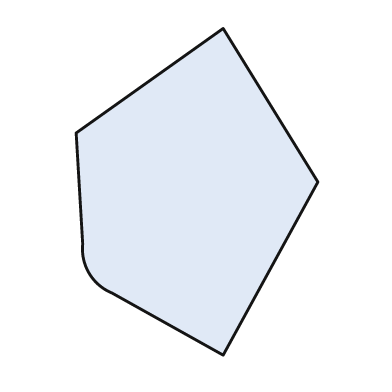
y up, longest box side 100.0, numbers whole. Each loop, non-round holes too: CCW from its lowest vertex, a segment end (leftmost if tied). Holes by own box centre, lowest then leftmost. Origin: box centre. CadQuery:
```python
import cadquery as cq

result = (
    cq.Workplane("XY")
    .moveTo(8.0, -50.0)
    .lineTo(37.0, 3.0)
    .lineTo(8.0, 50.0)
    .lineTo(-37.0, 18.0)
    .lineTo(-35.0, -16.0)
    .threePointArc((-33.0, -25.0), (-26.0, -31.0))
    .close()
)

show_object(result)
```